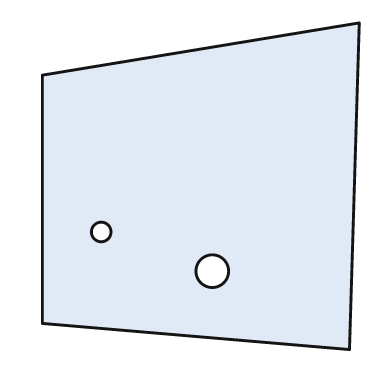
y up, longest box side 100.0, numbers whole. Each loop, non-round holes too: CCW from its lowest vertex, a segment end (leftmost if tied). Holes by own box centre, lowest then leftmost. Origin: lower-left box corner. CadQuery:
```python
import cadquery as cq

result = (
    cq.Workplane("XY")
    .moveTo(94.0, 0.0)
    .lineTo(97.0, 100.0)
    .lineTo(0.0, 84.0)
    .lineTo(0.0, 8.0)
    .close()
    .moveTo(52.0, 24.0)
    .circle(5.0)
    .moveTo(18.0, 36.0)
    .circle(3.0)
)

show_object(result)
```